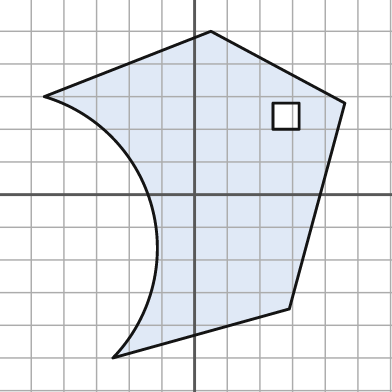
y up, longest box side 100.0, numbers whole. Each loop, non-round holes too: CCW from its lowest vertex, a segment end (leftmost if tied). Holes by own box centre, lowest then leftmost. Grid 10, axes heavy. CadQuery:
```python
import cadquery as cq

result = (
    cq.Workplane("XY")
    .moveTo(-25.0, -50.0)
    .lineTo(29.0, -35.0)
    .lineTo(46.0, 28.0)
    .lineTo(5.0, 50.0)
    .lineTo(-46.0, 30.0)
    .threePointArc((-13.0, -4.0), (-25.0, -50.0))
    .close()
    .moveTo(24.0, 20.0)
    .lineTo(32.0, 20.0)
    .lineTo(32.0, 28.0)
    .lineTo(24.0, 28.0)
    .close()
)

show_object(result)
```